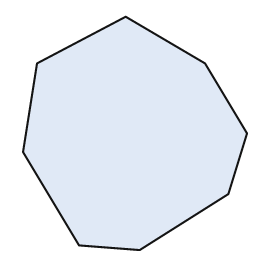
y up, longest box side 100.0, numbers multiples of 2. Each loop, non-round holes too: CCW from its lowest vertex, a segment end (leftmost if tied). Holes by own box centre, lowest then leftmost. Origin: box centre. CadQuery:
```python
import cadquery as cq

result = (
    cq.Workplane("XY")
    .moveTo(2.0, -50.0)
    .lineTo(40.0, -26.0)
    .lineTo(48.0, 0.0)
    .lineTo(30.0, 30.0)
    .lineTo(-4.0, 50.0)
    .lineTo(-42.0, 30.0)
    .lineTo(-48.0, -8.0)
    .lineTo(-24.0, -48.0)
    .close()
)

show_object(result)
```